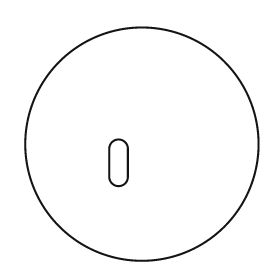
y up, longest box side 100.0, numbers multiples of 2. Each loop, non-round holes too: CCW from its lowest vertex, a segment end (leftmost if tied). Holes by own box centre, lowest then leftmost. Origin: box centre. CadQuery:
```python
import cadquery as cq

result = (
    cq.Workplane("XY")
    .moveTo(0.0, 0.0)
    .circle(50.0)
    .moveTo(-14.0, -14.0)
    .threePointArc((-10.0, -18.0), (-6.0, -14.0))
    .lineTo(-6.0, -2.0)
    .threePointArc((-10.0, 2.0), (-14.0, -2.0))
    .close()
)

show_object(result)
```